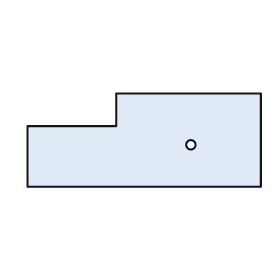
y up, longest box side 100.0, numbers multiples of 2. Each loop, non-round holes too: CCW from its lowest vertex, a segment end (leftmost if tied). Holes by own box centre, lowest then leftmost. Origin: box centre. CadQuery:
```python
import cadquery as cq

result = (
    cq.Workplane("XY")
    .moveTo(-50.0, -20.0)
    .lineTo(50.0, -20.0)
    .lineTo(50.0, 20.0)
    .lineTo(-12.0, 20.0)
    .lineTo(-12.0, 6.0)
    .lineTo(-50.0, 6.0)
    .close()
    .moveTo(20.0, -2.0)
    .circle(2.0)
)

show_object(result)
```